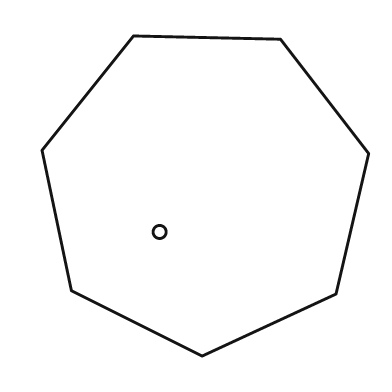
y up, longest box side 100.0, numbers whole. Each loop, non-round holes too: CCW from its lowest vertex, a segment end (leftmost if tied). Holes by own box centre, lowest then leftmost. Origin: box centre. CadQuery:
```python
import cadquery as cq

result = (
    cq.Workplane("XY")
    .moveTo(-1.0, -49.0)
    .lineTo(40.0, -30.0)
    .lineTo(50.0, 13.0)
    .lineTo(23.0, 48.0)
    .lineTo(-22.0, 49.0)
    .lineTo(-50.0, 14.0)
    .lineTo(-41.0, -29.0)
    .close()
    .moveTo(-14.0, -11.0)
    .circle(2.0)
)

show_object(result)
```